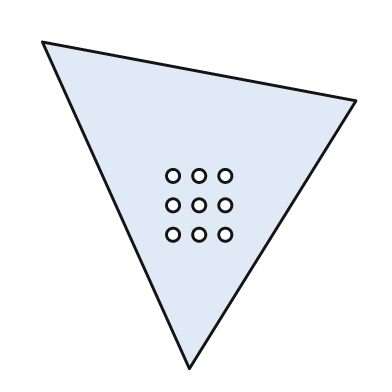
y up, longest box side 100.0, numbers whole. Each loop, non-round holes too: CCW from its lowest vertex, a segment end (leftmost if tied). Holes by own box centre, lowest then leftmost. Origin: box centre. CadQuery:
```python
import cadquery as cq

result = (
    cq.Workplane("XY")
    .moveTo(-3.0, -50.0)
    .lineTo(48.0, 32.0)
    .lineTo(-48.0, 50.0)
    .close()
    .moveTo(-8.0, -9.0)
    .circle(2.0)
    .moveTo(0.0, -9.0)
    .circle(2.0)
    .moveTo(8.0, -9.0)
    .circle(2.0)
    .moveTo(-8.0, 0.0)
    .circle(2.0)
    .moveTo(0.0, 0.0)
    .circle(2.0)
    .moveTo(8.0, 0.0)
    .circle(2.0)
    .moveTo(-8.0, 9.0)
    .circle(2.0)
    .moveTo(0.0, 9.0)
    .circle(2.0)
    .moveTo(8.0, 9.0)
    .circle(2.0)
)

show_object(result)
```